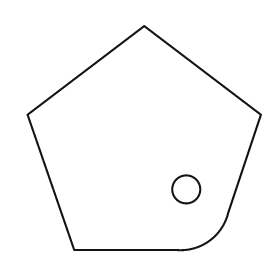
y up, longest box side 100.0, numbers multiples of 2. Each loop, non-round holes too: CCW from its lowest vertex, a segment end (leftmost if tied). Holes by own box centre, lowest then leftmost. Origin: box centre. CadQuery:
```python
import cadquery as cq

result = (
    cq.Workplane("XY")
    .moveTo(-30.0, -48.0)
    .lineTo(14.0, -48.0)
    .threePointArc((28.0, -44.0), (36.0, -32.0))
    .lineTo(50.0, 10.0)
    .lineTo(0.0, 48.0)
    .lineTo(-50.0, 10.0)
    .close()
    .moveTo(18.0, -22.0)
    .circle(6.0)
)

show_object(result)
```